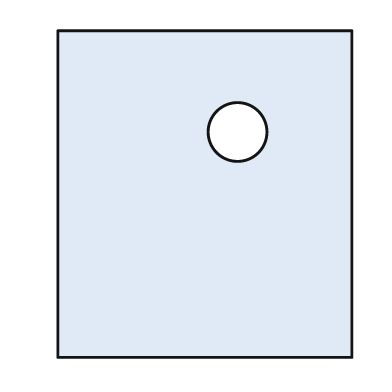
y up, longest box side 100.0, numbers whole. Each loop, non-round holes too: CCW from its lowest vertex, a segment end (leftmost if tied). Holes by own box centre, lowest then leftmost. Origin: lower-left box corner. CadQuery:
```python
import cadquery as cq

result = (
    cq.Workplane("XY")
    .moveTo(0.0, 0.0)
    .lineTo(90.0, 0.0)
    .lineTo(90.0, 100.0)
    .lineTo(0.0, 100.0)
    .close()
    .moveTo(55.0, 69.0)
    .circle(9.0)
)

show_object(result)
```